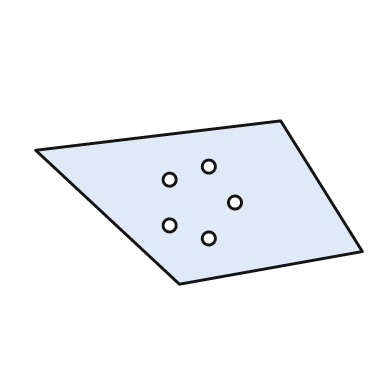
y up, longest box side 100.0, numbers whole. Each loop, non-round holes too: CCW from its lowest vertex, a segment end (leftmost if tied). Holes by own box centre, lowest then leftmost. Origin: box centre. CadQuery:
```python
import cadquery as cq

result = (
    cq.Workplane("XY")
    .moveTo(-6.0, -25.0)
    .lineTo(50.0, -15.0)
    .lineTo(25.0, 25.0)
    .lineTo(-50.0, 16.0)
    .close()
    .moveTo(3.0, -11.0)
    .circle(2.0)
    .moveTo(-9.0, -7.0)
    .circle(2.0)
    .moveTo(11.0, 0.0)
    .circle(2.0)
    .moveTo(-9.0, 7.0)
    .circle(2.0)
    .moveTo(3.0, 11.0)
    .circle(2.0)
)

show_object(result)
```